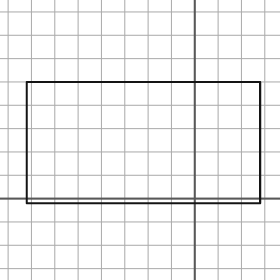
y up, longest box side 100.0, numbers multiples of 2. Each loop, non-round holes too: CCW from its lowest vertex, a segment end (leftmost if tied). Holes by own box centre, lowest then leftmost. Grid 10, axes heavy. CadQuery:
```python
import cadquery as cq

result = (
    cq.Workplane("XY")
    .moveTo(-72.0, -2.0)
    .lineTo(28.0, -2.0)
    .lineTo(28.0, 50.0)
    .lineTo(-72.0, 50.0)
    .close()
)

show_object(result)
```